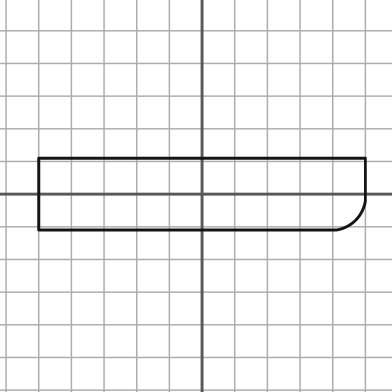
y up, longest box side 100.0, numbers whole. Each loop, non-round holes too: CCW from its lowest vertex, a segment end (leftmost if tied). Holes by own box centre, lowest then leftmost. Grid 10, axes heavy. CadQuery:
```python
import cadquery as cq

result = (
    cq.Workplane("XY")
    .moveTo(-50.0, -11.0)
    .lineTo(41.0, -11.0)
    .threePointArc((47.0, -8.0), (50.0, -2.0))
    .lineTo(50.0, 11.0)
    .lineTo(-50.0, 11.0)
    .close()
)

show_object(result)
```